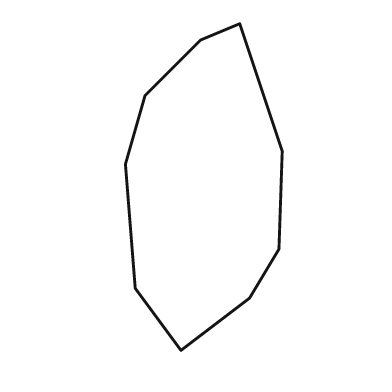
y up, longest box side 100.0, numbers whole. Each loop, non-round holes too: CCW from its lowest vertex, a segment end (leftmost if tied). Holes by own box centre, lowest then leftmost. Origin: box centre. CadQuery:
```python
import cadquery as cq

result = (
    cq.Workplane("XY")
    .moveTo(-7.0, -50.0)
    .lineTo(14.0, -34.0)
    .lineTo(23.0, -19.0)
    .lineTo(24.0, 11.0)
    .lineTo(11.0, 50.0)
    .lineTo(-1.0, 45.0)
    .lineTo(-18.0, 28.0)
    .lineTo(-24.0, 7.0)
    .lineTo(-21.0, -31.0)
    .close()
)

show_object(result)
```